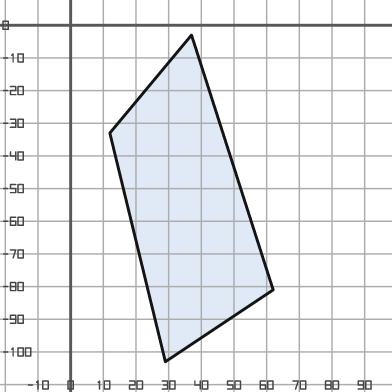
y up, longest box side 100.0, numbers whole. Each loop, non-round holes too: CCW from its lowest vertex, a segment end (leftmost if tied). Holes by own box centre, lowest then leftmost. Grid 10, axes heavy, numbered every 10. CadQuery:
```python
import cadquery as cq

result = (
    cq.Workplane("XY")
    .moveTo(29.0, -103.0)
    .lineTo(62.0, -81.0)
    .lineTo(37.0, -3.0)
    .lineTo(12.0, -33.0)
    .close()
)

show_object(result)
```